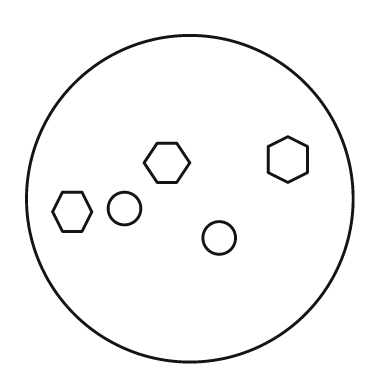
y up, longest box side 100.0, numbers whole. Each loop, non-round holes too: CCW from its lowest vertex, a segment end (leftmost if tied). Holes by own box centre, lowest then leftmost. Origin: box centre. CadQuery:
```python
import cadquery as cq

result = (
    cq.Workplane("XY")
    .moveTo(0.0, 0.0)
    .circle(50.0)
    .moveTo(9.0, -12.0)
    .circle(5.0)
    .moveTo(-39.0, -10.0)
    .lineTo(-33.0, -10.0)
    .lineTo(-30.0, -4.0)
    .lineTo(-33.0, 2.0)
    .lineTo(-39.0, 2.0)
    .lineTo(-42.0, -4.0)
    .close()
    .moveTo(-20.0, -3.0)
    .circle(5.0)
    .moveTo(-10.0, 5.0)
    .lineTo(-4.0, 5.0)
    .lineTo(0.0, 11.0)
    .lineTo(-4.0, 17.0)
    .lineTo(-10.0, 17.0)
    .lineTo(-14.0, 11.0)
    .close()
    .moveTo(30.0, 5.0)
    .lineTo(36.0, 8.0)
    .lineTo(36.0, 16.0)
    .lineTo(30.0, 19.0)
    .lineTo(24.0, 16.0)
    .lineTo(24.0, 8.0)
    .close()
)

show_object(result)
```